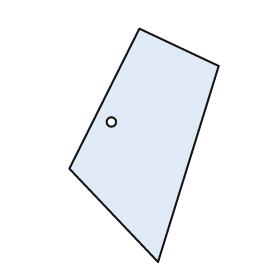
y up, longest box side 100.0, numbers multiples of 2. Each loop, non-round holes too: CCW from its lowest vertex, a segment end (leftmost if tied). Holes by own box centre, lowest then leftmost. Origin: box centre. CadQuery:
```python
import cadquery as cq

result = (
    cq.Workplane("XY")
    .moveTo(6.0, -50.0)
    .lineTo(32.0, 34.0)
    .lineTo(-2.0, 50.0)
    .lineTo(-32.0, -10.0)
    .close()
    .moveTo(-14.0, 10.0)
    .circle(2.0)
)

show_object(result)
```